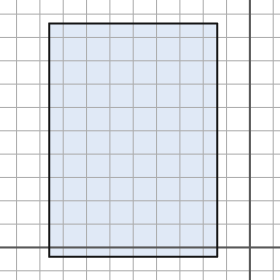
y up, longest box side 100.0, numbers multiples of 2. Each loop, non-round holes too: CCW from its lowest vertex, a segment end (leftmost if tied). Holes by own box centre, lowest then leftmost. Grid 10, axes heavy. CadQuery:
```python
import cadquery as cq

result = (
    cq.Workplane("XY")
    .moveTo(-86.0, -4.0)
    .lineTo(-14.0, -4.0)
    .lineTo(-14.0, 96.0)
    .lineTo(-86.0, 96.0)
    .close()
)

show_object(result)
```